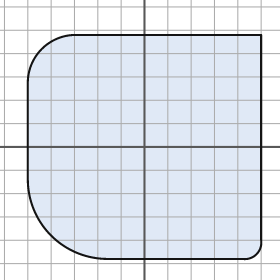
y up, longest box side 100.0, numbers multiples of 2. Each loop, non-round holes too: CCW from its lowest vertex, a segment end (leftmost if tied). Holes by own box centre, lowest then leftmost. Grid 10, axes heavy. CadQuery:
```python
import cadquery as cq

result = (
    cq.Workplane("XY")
    .moveTo(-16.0, -48.0)
    .lineTo(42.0, -48.0)
    .threePointArc((48.0, -46.0), (50.0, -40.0))
    .lineTo(50.0, 48.0)
    .lineTo(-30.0, 48.0)
    .threePointArc((-44.0, 42.0), (-50.0, 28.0))
    .lineTo(-50.0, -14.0)
    .threePointArc((-40.0, -38.0), (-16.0, -48.0))
    .close()
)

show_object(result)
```